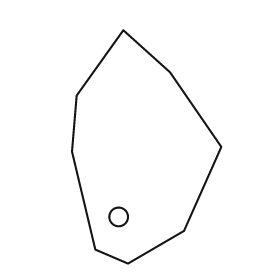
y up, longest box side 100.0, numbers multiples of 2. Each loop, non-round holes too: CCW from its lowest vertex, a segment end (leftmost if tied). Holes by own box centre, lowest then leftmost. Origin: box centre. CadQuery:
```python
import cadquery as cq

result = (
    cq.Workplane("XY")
    .moveTo(-8.0, -50.0)
    .lineTo(16.0, -36.0)
    .lineTo(32.0, 0.0)
    .lineTo(10.0, 32.0)
    .lineTo(-10.0, 50.0)
    .lineTo(-30.0, 22.0)
    .lineTo(-32.0, -2.0)
    .lineTo(-22.0, -44.0)
    .close()
    .moveTo(-12.0, -30.0)
    .circle(4.0)
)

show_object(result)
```